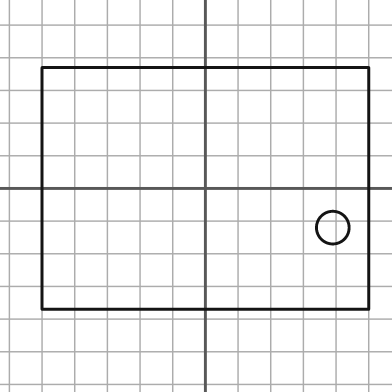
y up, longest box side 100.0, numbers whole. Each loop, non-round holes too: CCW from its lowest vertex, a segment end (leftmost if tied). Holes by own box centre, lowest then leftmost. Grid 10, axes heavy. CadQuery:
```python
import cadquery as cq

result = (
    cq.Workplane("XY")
    .moveTo(-50.0, -37.0)
    .lineTo(50.0, -37.0)
    .lineTo(50.0, 37.0)
    .lineTo(-50.0, 37.0)
    .close()
    .moveTo(39.0, -12.0)
    .circle(5.0)
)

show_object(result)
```